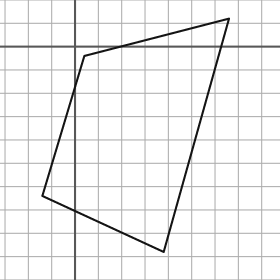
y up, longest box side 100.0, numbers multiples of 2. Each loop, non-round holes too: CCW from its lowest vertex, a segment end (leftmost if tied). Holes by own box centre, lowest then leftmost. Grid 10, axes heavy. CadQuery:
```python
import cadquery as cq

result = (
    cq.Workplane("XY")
    .moveTo(38.0, -88.0)
    .lineTo(66.0, 12.0)
    .lineTo(4.0, -4.0)
    .lineTo(-14.0, -64.0)
    .close()
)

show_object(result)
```